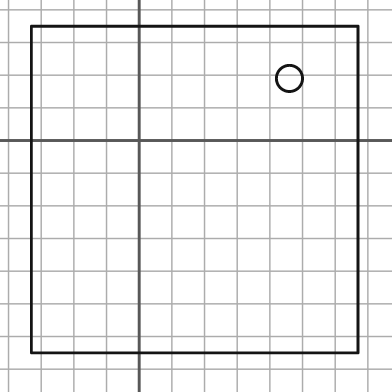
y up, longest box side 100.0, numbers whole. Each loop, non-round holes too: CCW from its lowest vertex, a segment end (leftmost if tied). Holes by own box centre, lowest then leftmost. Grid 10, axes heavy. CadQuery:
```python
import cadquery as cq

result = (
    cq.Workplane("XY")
    .moveTo(-33.0, -65.0)
    .lineTo(67.0, -65.0)
    .lineTo(67.0, 35.0)
    .lineTo(-33.0, 35.0)
    .close()
    .moveTo(46.0, 19.0)
    .circle(4.0)
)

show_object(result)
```